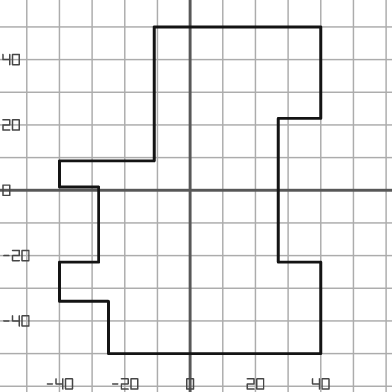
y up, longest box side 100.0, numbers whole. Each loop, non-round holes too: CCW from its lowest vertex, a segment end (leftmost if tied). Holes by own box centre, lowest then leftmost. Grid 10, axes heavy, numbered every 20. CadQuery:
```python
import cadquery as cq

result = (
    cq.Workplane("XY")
    .moveTo(-25.0, -50.0)
    .lineTo(40.0, -50.0)
    .lineTo(40.0, -22.0)
    .lineTo(27.0, -22.0)
    .lineTo(27.0, 22.0)
    .lineTo(40.0, 22.0)
    .lineTo(40.0, 50.0)
    .lineTo(-11.0, 50.0)
    .lineTo(-11.0, 9.0)
    .lineTo(-40.0, 9.0)
    .lineTo(-40.0, 1.0)
    .lineTo(-28.0, 1.0)
    .lineTo(-28.0, -22.0)
    .lineTo(-40.0, -22.0)
    .lineTo(-40.0, -34.0)
    .lineTo(-25.0, -34.0)
    .close()
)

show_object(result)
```